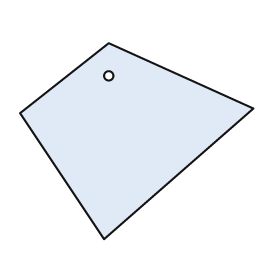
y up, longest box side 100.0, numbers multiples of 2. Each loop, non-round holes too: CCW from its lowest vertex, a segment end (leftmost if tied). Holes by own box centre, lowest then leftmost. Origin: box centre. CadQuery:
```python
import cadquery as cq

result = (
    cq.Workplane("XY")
    .moveTo(-14.0, -42.0)
    .lineTo(50.0, 14.0)
    .lineTo(-12.0, 42.0)
    .lineTo(-50.0, 12.0)
    .close()
    .moveTo(-12.0, 28.0)
    .circle(2.0)
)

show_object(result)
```